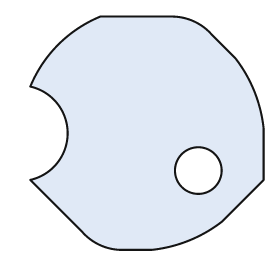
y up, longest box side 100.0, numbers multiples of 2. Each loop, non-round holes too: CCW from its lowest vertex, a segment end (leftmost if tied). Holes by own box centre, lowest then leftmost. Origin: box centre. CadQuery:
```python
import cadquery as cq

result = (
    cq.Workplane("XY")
    .moveTo(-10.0, -50.0)
    .lineTo(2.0, -50.0)
    .threePointArc((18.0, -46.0), (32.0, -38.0))
    .lineTo(50.0, -20.0)
    .lineTo(50.0, 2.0)
    .threePointArc((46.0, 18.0), (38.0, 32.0))
    .lineTo(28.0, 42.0)
    .threePointArc((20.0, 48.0), (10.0, 50.0))
    .lineTo(-20.0, 50.0)
    .threePointArc((-38.0, 38.0), (-50.0, 20.0))
    .threePointArc((-34.0, 0.0), (-50.0, -20.0))
    .lineTo(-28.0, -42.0)
    .threePointArc((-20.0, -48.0), (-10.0, -50.0))
    .close()
    .moveTo(22.0, -16.0)
    .circle(10.0)
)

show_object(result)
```